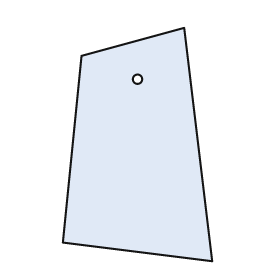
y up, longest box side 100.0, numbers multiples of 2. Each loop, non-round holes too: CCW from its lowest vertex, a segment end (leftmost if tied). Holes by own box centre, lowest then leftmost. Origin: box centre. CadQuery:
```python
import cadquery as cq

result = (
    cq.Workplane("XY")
    .moveTo(32.0, -50.0)
    .lineTo(20.0, 50.0)
    .lineTo(-24.0, 38.0)
    .lineTo(-32.0, -42.0)
    .close()
    .moveTo(0.0, 28.0)
    .circle(2.0)
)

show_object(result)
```